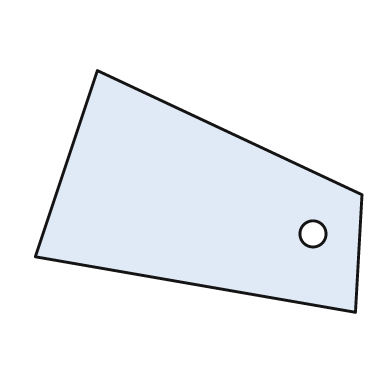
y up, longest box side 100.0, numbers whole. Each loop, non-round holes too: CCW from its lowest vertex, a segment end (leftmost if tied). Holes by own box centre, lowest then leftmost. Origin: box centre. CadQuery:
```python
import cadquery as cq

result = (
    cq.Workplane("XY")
    .moveTo(48.0, -37.0)
    .lineTo(50.0, -1.0)
    .lineTo(-31.0, 37.0)
    .lineTo(-50.0, -20.0)
    .close()
    .moveTo(35.0, -13.0)
    .circle(4.0)
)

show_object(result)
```